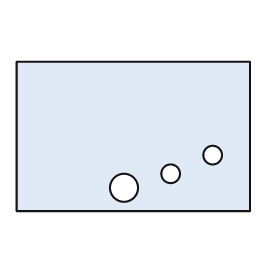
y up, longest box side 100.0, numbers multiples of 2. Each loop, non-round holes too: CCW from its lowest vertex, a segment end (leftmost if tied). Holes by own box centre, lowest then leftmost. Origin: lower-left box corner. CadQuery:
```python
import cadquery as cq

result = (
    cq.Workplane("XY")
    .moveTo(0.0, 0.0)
    .lineTo(100.0, 0.0)
    .lineTo(100.0, 64.0)
    .lineTo(0.0, 64.0)
    .close()
    .moveTo(46.0, 10.0)
    .circle(6.0)
    .moveTo(66.0, 16.0)
    .circle(4.0)
    .moveTo(84.0, 24.0)
    .circle(4.0)
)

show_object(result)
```